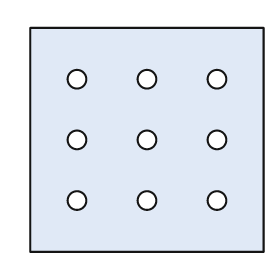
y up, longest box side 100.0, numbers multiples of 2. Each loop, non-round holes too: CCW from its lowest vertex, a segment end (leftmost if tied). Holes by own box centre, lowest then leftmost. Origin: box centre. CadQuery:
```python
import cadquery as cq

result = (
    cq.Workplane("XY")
    .moveTo(-50.0, -48.0)
    .lineTo(50.0, -48.0)
    .lineTo(50.0, 48.0)
    .lineTo(-50.0, 48.0)
    .close()
    .moveTo(-30.0, -26.0)
    .circle(4.0)
    .moveTo(0.0, -26.0)
    .circle(4.0)
    .moveTo(30.0, -26.0)
    .circle(4.0)
    .moveTo(-30.0, 0.0)
    .circle(4.0)
    .moveTo(0.0, 0.0)
    .circle(4.0)
    .moveTo(30.0, 0.0)
    .circle(4.0)
    .moveTo(-30.0, 26.0)
    .circle(4.0)
    .moveTo(0.0, 26.0)
    .circle(4.0)
    .moveTo(30.0, 26.0)
    .circle(4.0)
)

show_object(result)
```